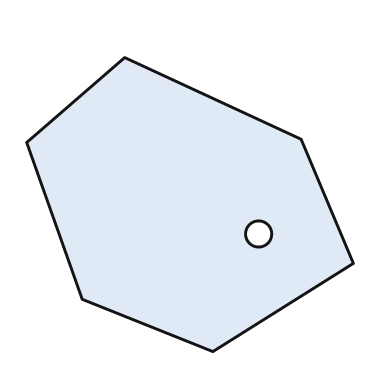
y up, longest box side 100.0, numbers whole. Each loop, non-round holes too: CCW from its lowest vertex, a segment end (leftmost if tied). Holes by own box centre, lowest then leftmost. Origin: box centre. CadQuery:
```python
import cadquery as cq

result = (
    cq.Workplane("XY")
    .moveTo(7.0, -45.0)
    .lineTo(50.0, -18.0)
    .lineTo(34.0, 20.0)
    .lineTo(-20.0, 45.0)
    .lineTo(-50.0, 19.0)
    .lineTo(-33.0, -29.0)
    .close()
    .moveTo(21.0, -9.0)
    .circle(4.0)
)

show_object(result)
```